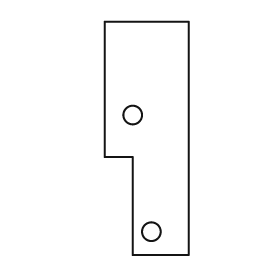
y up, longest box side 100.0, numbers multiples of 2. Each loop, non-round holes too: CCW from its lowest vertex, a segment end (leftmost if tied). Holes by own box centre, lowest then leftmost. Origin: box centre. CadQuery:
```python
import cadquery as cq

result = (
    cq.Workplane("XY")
    .moveTo(-6.0, -50.0)
    .lineTo(18.0, -50.0)
    .lineTo(18.0, 50.0)
    .lineTo(-18.0, 50.0)
    .lineTo(-18.0, -8.0)
    .lineTo(-6.0, -8.0)
    .close()
    .moveTo(2.0, -40.0)
    .circle(4.0)
    .moveTo(-6.0, 10.0)
    .circle(4.0)
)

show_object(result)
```